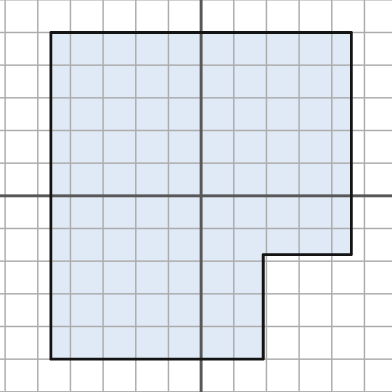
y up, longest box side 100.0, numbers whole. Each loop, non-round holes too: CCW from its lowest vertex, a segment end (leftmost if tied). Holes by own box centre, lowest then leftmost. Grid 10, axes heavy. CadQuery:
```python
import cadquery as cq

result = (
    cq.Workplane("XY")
    .moveTo(-46.0, -50.0)
    .lineTo(19.0, -50.0)
    .lineTo(19.0, -18.0)
    .lineTo(46.0, -18.0)
    .lineTo(46.0, 50.0)
    .lineTo(-46.0, 50.0)
    .close()
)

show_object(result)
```